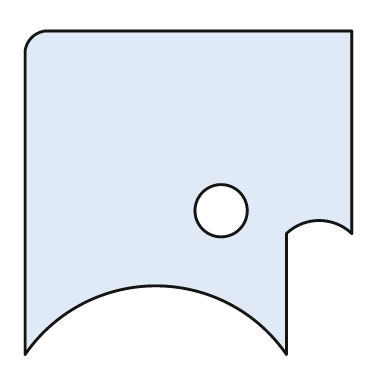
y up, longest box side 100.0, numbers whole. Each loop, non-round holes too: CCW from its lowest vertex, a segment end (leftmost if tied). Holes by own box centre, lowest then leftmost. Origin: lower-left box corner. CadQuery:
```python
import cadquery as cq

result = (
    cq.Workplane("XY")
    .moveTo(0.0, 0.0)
    .threePointArc((40.0, 21.0), (80.0, 0.0))
    .lineTo(80.0, 37.0)
    .threePointArc((90.0, 41.0), (100.0, 37.0))
    .lineTo(100.0, 99.0)
    .lineTo(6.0, 99.0)
    .threePointArc((2.0, 97.0), (0.0, 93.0))
    .close()
    .moveTo(60.0, 44.0)
    .circle(8.0)
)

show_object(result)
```